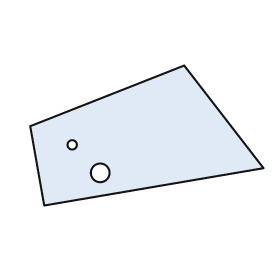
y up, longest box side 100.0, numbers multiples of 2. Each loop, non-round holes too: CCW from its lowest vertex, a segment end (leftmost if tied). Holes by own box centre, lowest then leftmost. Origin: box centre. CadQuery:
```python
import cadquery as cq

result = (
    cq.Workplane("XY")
    .moveTo(-44.0, -30.0)
    .lineTo(50.0, -14.0)
    .lineTo(16.0, 30.0)
    .lineTo(-50.0, 4.0)
    .close()
    .moveTo(-20.0, -16.0)
    .circle(4.0)
    .moveTo(-32.0, -4.0)
    .circle(2.0)
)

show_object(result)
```